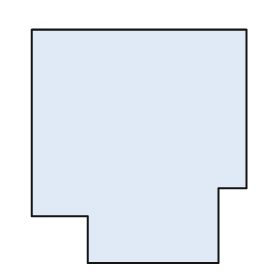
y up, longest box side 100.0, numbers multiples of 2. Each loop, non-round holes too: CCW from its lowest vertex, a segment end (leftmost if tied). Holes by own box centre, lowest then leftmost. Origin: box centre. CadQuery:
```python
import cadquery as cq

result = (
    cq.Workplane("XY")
    .moveTo(-22.0, -50.0)
    .lineTo(34.0, -50.0)
    .lineTo(34.0, -18.0)
    .lineTo(46.0, -18.0)
    .lineTo(46.0, 50.0)
    .lineTo(-46.0, 50.0)
    .lineTo(-46.0, -30.0)
    .lineTo(-22.0, -30.0)
    .close()
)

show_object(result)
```